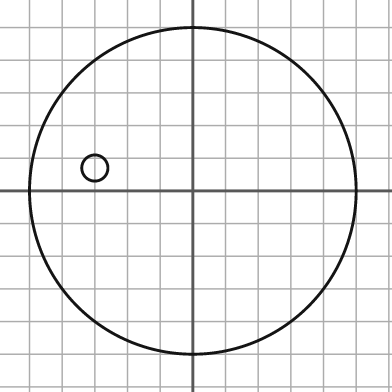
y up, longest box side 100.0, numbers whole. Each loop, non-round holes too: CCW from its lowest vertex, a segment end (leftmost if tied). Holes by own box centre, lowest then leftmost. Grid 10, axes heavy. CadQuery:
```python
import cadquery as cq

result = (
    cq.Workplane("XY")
    .moveTo(0.0, 0.0)
    .circle(50.0)
    .moveTo(-30.0, 7.0)
    .circle(4.0)
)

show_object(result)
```